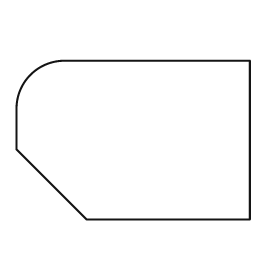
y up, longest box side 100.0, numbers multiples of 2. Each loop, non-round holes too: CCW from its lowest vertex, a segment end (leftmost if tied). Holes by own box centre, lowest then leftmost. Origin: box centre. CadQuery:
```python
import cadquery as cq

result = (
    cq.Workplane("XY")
    .moveTo(-20.0, -34.0)
    .lineTo(50.0, -34.0)
    .lineTo(50.0, 34.0)
    .lineTo(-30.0, 34.0)
    .threePointArc((-44.0, 28.0), (-50.0, 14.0))
    .lineTo(-50.0, -4.0)
    .close()
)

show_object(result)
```